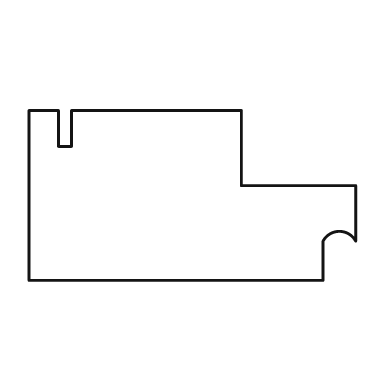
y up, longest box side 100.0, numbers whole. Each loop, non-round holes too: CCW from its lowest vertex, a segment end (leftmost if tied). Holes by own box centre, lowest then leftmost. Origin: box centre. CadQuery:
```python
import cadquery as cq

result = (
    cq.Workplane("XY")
    .moveTo(-50.0, -26.0)
    .lineTo(40.0, -26.0)
    .lineTo(40.0, -14.0)
    .threePointArc((45.0, -11.0), (50.0, -14.0))
    .lineTo(50.0, 3.0)
    .lineTo(15.0, 3.0)
    .lineTo(15.0, 26.0)
    .lineTo(-37.0, 26.0)
    .lineTo(-37.0, 15.0)
    .lineTo(-41.0, 15.0)
    .lineTo(-41.0, 26.0)
    .lineTo(-50.0, 26.0)
    .close()
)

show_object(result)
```